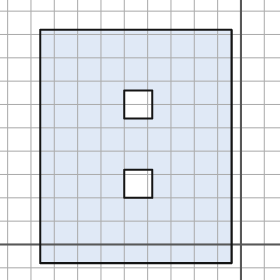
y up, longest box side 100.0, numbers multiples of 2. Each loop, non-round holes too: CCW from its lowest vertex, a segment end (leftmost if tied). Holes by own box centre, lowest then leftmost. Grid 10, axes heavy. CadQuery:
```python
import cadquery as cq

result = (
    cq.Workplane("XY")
    .moveTo(-86.0, -8.0)
    .lineTo(-4.0, -8.0)
    .lineTo(-4.0, 92.0)
    .lineTo(-86.0, 92.0)
    .close()
    .moveTo(-50.0, 20.0)
    .lineTo(-38.0, 20.0)
    .lineTo(-38.0, 32.0)
    .lineTo(-50.0, 32.0)
    .close()
    .moveTo(-50.0, 54.0)
    .lineTo(-38.0, 54.0)
    .lineTo(-38.0, 66.0)
    .lineTo(-50.0, 66.0)
    .close()
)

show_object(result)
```